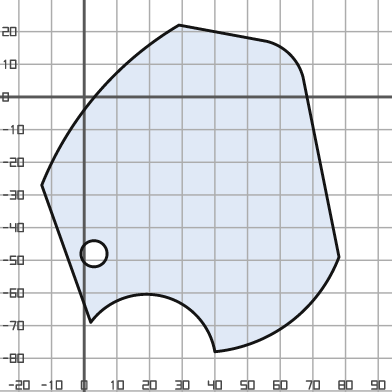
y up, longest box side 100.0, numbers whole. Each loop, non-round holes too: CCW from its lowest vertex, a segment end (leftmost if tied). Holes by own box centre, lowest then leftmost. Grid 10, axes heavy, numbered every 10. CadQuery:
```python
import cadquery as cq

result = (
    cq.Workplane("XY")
    .moveTo(40.0, -78.0)
    .threePointArc((63.0, -69.0), (78.0, -49.0))
    .lineTo(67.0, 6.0)
    .threePointArc((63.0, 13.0), (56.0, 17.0))
    .lineTo(29.0, 22.0)
    .threePointArc((4.0, 1.0), (-13.0, -27.0))
    .lineTo(2.0, -69.0)
    .threePointArc((24.0, -61.0), (40.0, -78.0))
    .close()
    .moveTo(3.0, -48.0)
    .circle(4.0)
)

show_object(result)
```